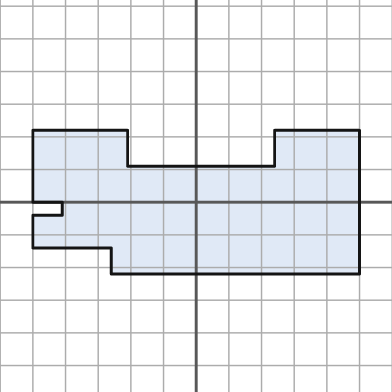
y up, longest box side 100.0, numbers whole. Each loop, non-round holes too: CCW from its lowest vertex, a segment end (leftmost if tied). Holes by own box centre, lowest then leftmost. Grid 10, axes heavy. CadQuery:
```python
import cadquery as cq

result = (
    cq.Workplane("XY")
    .moveTo(-26.0, -22.0)
    .lineTo(50.0, -22.0)
    .lineTo(50.0, 22.0)
    .lineTo(24.0, 22.0)
    .lineTo(24.0, 11.0)
    .lineTo(-21.0, 11.0)
    .lineTo(-21.0, 22.0)
    .lineTo(-50.0, 22.0)
    .lineTo(-50.0, 0.0)
    .lineTo(-41.0, 0.0)
    .lineTo(-41.0, -4.0)
    .lineTo(-50.0, -4.0)
    .lineTo(-50.0, -14.0)
    .lineTo(-26.0, -14.0)
    .close()
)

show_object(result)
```